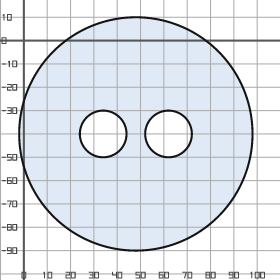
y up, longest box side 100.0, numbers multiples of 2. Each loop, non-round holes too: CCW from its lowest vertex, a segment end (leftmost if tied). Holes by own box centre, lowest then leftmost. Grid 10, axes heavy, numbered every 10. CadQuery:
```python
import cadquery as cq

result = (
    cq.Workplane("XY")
    .moveTo(48.0, -40.0)
    .circle(50.0)
    .moveTo(34.0, -40.0)
    .circle(10.0)
    .moveTo(62.0, -40.0)
    .circle(10.0)
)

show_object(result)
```